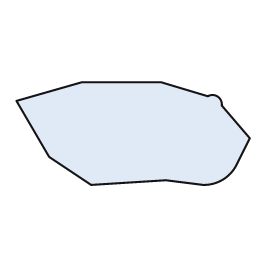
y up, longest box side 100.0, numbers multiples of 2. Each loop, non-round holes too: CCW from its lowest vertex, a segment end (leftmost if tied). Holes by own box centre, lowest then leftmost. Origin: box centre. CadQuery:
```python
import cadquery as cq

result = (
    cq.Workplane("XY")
    .moveTo(-18.0, -22.0)
    .lineTo(14.0, -20.0)
    .lineTo(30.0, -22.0)
    .threePointArc((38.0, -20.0), (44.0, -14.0))
    .lineTo(50.0, -2.0)
    .lineTo(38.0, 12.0)
    .threePointArc((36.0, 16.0), (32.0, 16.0))
    .lineTo(12.0, 22.0)
    .lineTo(-22.0, 22.0)
    .lineTo(-50.0, 14.0)
    .lineTo(-36.0, -10.0)
    .close()
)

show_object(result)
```